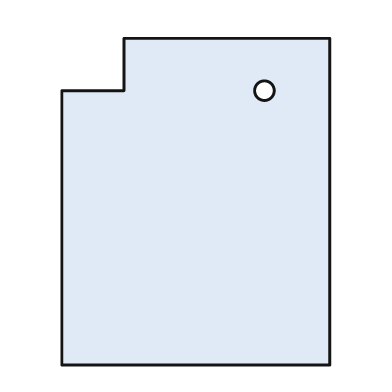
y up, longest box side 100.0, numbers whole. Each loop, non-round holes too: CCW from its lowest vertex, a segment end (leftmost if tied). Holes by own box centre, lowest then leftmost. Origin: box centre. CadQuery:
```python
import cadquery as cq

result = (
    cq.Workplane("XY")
    .moveTo(-41.0, -50.0)
    .lineTo(41.0, -50.0)
    .lineTo(41.0, 50.0)
    .lineTo(-22.0, 50.0)
    .lineTo(-22.0, 34.0)
    .lineTo(-41.0, 34.0)
    .close()
    .moveTo(21.0, 34.0)
    .circle(3.0)
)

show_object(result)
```